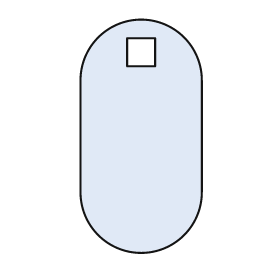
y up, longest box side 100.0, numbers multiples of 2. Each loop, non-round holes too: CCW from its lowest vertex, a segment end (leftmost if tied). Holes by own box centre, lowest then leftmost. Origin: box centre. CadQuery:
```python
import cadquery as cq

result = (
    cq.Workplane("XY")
    .moveTo(-26.0, -24.0)
    .threePointArc((0.0, -50.0), (26.0, -24.0))
    .lineTo(26.0, 24.0)
    .threePointArc((0.0, 50.0), (-26.0, 24.0))
    .close()
    .moveTo(-6.0, 30.0)
    .lineTo(6.0, 30.0)
    .lineTo(6.0, 42.0)
    .lineTo(-6.0, 42.0)
    .close()
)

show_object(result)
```